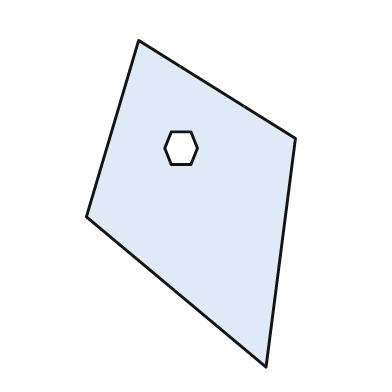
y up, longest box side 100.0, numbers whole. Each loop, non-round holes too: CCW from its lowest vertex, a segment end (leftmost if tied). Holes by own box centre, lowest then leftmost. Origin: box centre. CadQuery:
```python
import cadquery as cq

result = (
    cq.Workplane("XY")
    .moveTo(23.0, -50.0)
    .lineTo(32.0, 20.0)
    .lineTo(-16.0, 50.0)
    .lineTo(-32.0, -4.0)
    .close()
    .moveTo(-6.0, 12.0)
    .lineTo(0.0, 12.0)
    .lineTo(2.0, 17.0)
    .lineTo(0.0, 22.0)
    .lineTo(-6.0, 22.0)
    .lineTo(-8.0, 17.0)
    .close()
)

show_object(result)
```